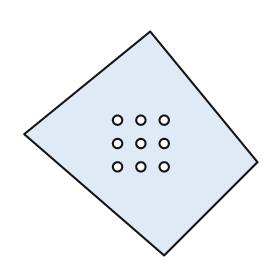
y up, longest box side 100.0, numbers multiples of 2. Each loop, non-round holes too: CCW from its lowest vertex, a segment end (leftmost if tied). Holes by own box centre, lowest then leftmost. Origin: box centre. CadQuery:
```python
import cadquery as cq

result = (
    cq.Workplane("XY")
    .moveTo(10.0, -48.0)
    .lineTo(50.0, -8.0)
    .lineTo(4.0, 48.0)
    .lineTo(-50.0, 4.0)
    .close()
    .moveTo(-10.0, -10.0)
    .circle(2.0)
    .moveTo(0.0, -10.0)
    .circle(2.0)
    .moveTo(10.0, -10.0)
    .circle(2.0)
    .moveTo(-10.0, 0.0)
    .circle(2.0)
    .moveTo(0.0, 0.0)
    .circle(2.0)
    .moveTo(10.0, 0.0)
    .circle(2.0)
    .moveTo(-10.0, 10.0)
    .circle(2.0)
    .moveTo(0.0, 10.0)
    .circle(2.0)
    .moveTo(10.0, 10.0)
    .circle(2.0)
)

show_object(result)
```